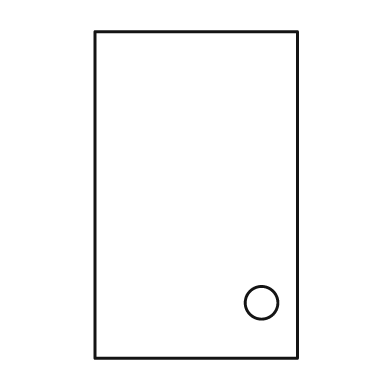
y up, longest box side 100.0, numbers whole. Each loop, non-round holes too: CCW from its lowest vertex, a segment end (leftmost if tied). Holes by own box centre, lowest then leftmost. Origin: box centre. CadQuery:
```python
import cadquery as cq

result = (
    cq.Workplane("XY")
    .moveTo(-31.0, -50.0)
    .lineTo(31.0, -50.0)
    .lineTo(31.0, 50.0)
    .lineTo(-31.0, 50.0)
    .close()
    .moveTo(20.0, -33.0)
    .circle(5.0)
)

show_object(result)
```